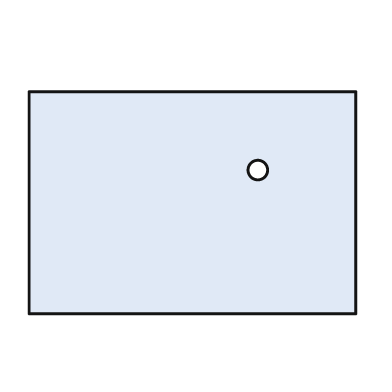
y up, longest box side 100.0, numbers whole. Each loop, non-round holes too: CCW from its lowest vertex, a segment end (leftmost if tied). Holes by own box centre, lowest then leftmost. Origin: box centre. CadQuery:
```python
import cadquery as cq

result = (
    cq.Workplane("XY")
    .moveTo(-50.0, -34.0)
    .lineTo(50.0, -34.0)
    .lineTo(50.0, 34.0)
    .lineTo(-50.0, 34.0)
    .close()
    .moveTo(20.0, 10.0)
    .circle(3.0)
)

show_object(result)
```